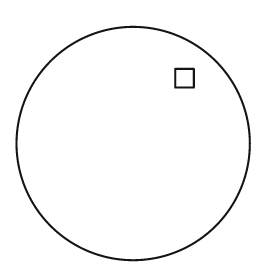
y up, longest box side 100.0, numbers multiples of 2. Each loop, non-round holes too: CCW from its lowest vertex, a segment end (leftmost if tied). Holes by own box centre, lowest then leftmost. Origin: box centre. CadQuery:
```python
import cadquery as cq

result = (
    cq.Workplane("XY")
    .moveTo(0.0, 0.0)
    .circle(50.0)
    .moveTo(18.0, 24.0)
    .lineTo(26.0, 24.0)
    .lineTo(26.0, 32.0)
    .lineTo(18.0, 32.0)
    .close()
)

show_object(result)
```